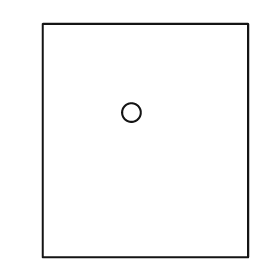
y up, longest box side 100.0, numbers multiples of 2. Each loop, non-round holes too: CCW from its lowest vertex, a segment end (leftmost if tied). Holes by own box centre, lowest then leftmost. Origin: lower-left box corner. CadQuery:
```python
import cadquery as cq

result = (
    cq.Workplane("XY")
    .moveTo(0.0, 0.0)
    .lineTo(88.0, 0.0)
    .lineTo(88.0, 100.0)
    .lineTo(0.0, 100.0)
    .close()
    .moveTo(38.0, 62.0)
    .circle(4.0)
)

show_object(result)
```